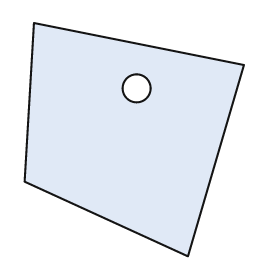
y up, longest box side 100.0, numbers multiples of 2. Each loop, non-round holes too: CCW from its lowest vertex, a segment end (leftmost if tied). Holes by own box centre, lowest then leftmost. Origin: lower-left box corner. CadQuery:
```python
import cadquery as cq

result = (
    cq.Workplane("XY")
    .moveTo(70.0, 0.0)
    .lineTo(94.0, 82.0)
    .lineTo(4.0, 100.0)
    .lineTo(0.0, 32.0)
    .close()
    .moveTo(48.0, 72.0)
    .circle(6.0)
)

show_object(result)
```